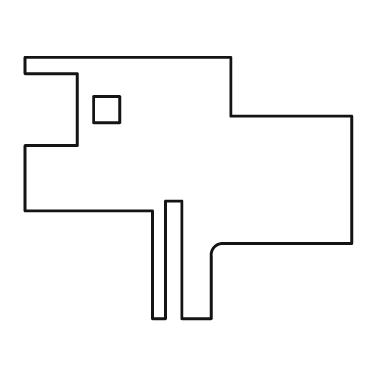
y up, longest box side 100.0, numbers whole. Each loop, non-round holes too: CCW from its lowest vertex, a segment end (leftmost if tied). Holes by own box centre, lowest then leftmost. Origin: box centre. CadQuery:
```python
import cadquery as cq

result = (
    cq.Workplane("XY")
    .moveTo(-11.0, -40.0)
    .lineTo(-7.0, -40.0)
    .lineTo(-7.0, -4.0)
    .lineTo(-2.0, -4.0)
    .lineTo(-2.0, -40.0)
    .lineTo(7.0, -40.0)
    .lineTo(7.0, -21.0)
    .threePointArc((8.0, -18.0), (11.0, -17.0))
    .lineTo(50.0, -17.0)
    .lineTo(50.0, 22.0)
    .lineTo(13.0, 22.0)
    .lineTo(13.0, 40.0)
    .lineTo(-50.0, 40.0)
    .lineTo(-50.0, 35.0)
    .lineTo(-34.0, 35.0)
    .lineTo(-34.0, 13.0)
    .lineTo(-50.0, 13.0)
    .lineTo(-50.0, -7.0)
    .lineTo(-11.0, -7.0)
    .close()
    .moveTo(-29.0, 20.0)
    .lineTo(-21.0, 20.0)
    .lineTo(-21.0, 28.0)
    .lineTo(-29.0, 28.0)
    .close()
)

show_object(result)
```